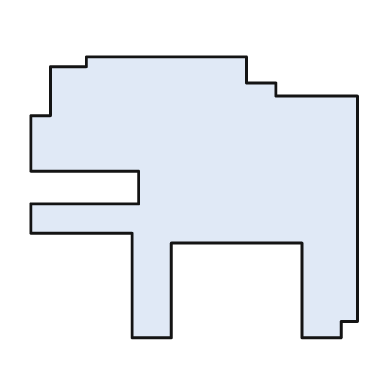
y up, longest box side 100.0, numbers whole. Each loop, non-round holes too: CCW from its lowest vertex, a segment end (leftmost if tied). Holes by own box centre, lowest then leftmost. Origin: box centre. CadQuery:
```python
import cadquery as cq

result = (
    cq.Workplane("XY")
    .moveTo(-19.0, -43.0)
    .lineTo(-7.0, -43.0)
    .lineTo(-7.0, -14.0)
    .lineTo(33.0, -14.0)
    .lineTo(33.0, -43.0)
    .lineTo(45.0, -43.0)
    .lineTo(45.0, -38.0)
    .lineTo(50.0, -38.0)
    .lineTo(50.0, 31.0)
    .lineTo(25.0, 31.0)
    .lineTo(25.0, 35.0)
    .lineTo(16.0, 35.0)
    .lineTo(16.0, 43.0)
    .lineTo(-33.0, 43.0)
    .lineTo(-33.0, 40.0)
    .lineTo(-44.0, 40.0)
    .lineTo(-44.0, 25.0)
    .lineTo(-50.0, 25.0)
    .lineTo(-50.0, 8.0)
    .lineTo(-17.0, 8.0)
    .lineTo(-17.0, -2.0)
    .lineTo(-50.0, -2.0)
    .lineTo(-50.0, -11.0)
    .lineTo(-19.0, -11.0)
    .close()
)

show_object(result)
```